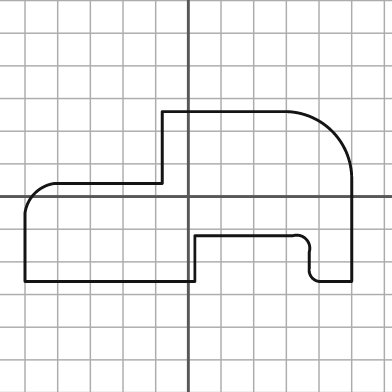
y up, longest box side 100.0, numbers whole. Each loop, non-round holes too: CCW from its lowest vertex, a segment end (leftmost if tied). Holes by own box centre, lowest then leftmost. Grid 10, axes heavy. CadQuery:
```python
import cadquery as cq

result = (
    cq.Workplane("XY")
    .moveTo(-50.0, -26.0)
    .lineTo(2.0, -26.0)
    .lineTo(2.0, -12.0)
    .lineTo(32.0, -12.0)
    .threePointArc((36.0, -13.0), (37.0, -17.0))
    .lineTo(37.0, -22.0)
    .threePointArc((38.0, -25.0), (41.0, -26.0))
    .lineTo(50.0, -26.0)
    .lineTo(50.0, 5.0)
    .threePointArc((44.0, 20.0), (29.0, 26.0))
    .lineTo(-8.0, 26.0)
    .lineTo(-8.0, 4.0)
    .lineTo(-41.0, 4.0)
    .threePointArc((-47.0, 1.0), (-50.0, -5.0))
    .close()
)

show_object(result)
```